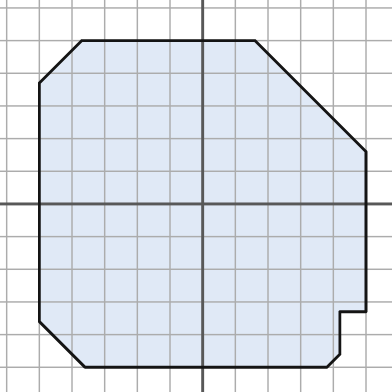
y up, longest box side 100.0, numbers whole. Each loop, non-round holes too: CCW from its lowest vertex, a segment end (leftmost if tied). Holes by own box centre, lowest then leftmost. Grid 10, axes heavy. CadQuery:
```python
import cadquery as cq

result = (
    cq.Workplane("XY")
    .moveTo(-36.0, -50.0)
    .lineTo(38.0, -50.0)
    .lineTo(42.0, -46.0)
    .lineTo(42.0, -33.0)
    .lineTo(50.0, -33.0)
    .lineTo(50.0, 16.0)
    .lineTo(16.0, 50.0)
    .lineTo(-37.0, 50.0)
    .lineTo(-50.0, 37.0)
    .lineTo(-50.0, -36.0)
    .close()
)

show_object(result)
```